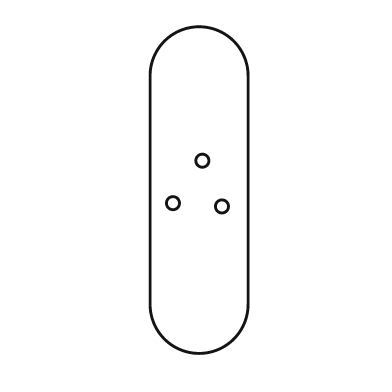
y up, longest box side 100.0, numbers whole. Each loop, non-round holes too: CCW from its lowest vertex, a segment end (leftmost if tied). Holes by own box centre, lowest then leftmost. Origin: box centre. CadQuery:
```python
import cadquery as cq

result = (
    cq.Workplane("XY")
    .moveTo(-15.0, -35.0)
    .threePointArc((0.0, -50.0), (15.0, -35.0))
    .lineTo(15.0, 35.0)
    .threePointArc((0.0, 50.0), (-15.0, 35.0))
    .close()
    .moveTo(7.0, -5.0)
    .circle(2.0)
    .moveTo(-8.0, -4.0)
    .circle(2.0)
    .moveTo(1.0, 9.0)
    .circle(2.0)
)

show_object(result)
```